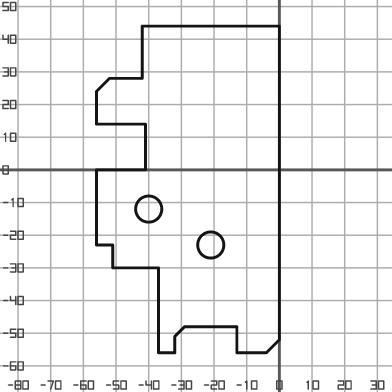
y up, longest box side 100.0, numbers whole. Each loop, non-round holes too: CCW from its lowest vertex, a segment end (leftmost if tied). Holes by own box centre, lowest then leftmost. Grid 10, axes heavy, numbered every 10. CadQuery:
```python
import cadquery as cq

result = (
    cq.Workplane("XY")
    .moveTo(-37.0, -56.0)
    .lineTo(-32.0, -56.0)
    .lineTo(-32.0, -51.0)
    .lineTo(-29.0, -48.0)
    .lineTo(-13.0, -48.0)
    .lineTo(-13.0, -56.0)
    .lineTo(-4.0, -56.0)
    .lineTo(0.0, -52.0)
    .lineTo(0.0, 44.0)
    .lineTo(-42.0, 44.0)
    .lineTo(-42.0, 28.0)
    .lineTo(-52.0, 28.0)
    .lineTo(-56.0, 24.0)
    .lineTo(-56.0, 14.0)
    .lineTo(-41.0, 14.0)
    .lineTo(-41.0, 0.0)
    .lineTo(-56.0, 0.0)
    .lineTo(-56.0, -23.0)
    .lineTo(-51.0, -23.0)
    .lineTo(-51.0, -30.0)
    .lineTo(-37.0, -30.0)
    .close()
    .moveTo(-21.0, -23.0)
    .circle(4.0)
    .moveTo(-40.0, -12.0)
    .circle(4.0)
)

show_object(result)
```